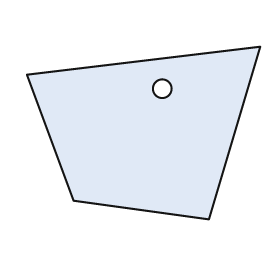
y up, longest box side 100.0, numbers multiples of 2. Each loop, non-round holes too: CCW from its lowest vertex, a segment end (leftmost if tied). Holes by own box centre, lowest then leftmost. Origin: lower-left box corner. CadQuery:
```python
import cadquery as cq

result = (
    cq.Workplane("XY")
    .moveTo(78.0, 0.0)
    .lineTo(100.0, 74.0)
    .lineTo(0.0, 62.0)
    .lineTo(20.0, 8.0)
    .close()
    .moveTo(58.0, 56.0)
    .circle(4.0)
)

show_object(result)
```